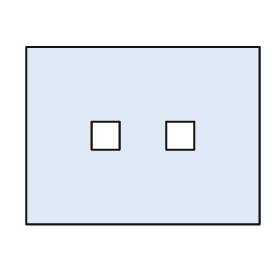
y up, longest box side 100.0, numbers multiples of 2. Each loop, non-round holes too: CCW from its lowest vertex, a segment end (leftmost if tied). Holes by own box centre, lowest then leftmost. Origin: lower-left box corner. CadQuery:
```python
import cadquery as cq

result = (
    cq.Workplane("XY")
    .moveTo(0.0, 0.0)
    .lineTo(100.0, 0.0)
    .lineTo(100.0, 76.0)
    .lineTo(0.0, 76.0)
    .close()
    .moveTo(28.0, 32.0)
    .lineTo(40.0, 32.0)
    .lineTo(40.0, 44.0)
    .lineTo(28.0, 44.0)
    .close()
    .moveTo(60.0, 32.0)
    .lineTo(72.0, 32.0)
    .lineTo(72.0, 44.0)
    .lineTo(60.0, 44.0)
    .close()
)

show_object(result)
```